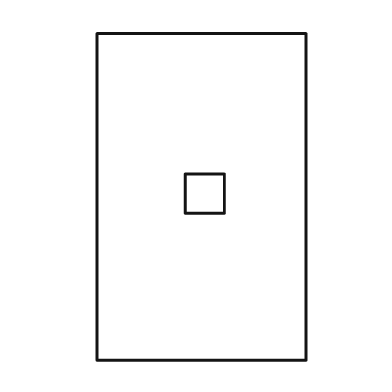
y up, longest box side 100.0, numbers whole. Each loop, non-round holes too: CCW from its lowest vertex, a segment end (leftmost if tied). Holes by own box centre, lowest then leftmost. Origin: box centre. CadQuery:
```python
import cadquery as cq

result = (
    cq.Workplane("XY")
    .moveTo(-32.0, -50.0)
    .lineTo(32.0, -50.0)
    .lineTo(32.0, 50.0)
    .lineTo(-32.0, 50.0)
    .close()
    .moveTo(-5.0, -5.0)
    .lineTo(7.0, -5.0)
    .lineTo(7.0, 7.0)
    .lineTo(-5.0, 7.0)
    .close()
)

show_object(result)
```